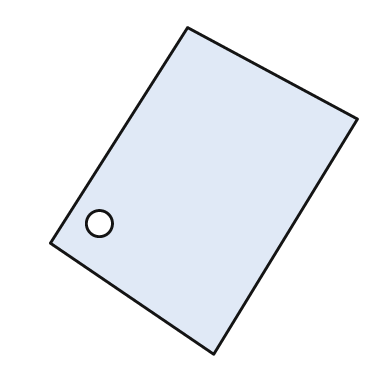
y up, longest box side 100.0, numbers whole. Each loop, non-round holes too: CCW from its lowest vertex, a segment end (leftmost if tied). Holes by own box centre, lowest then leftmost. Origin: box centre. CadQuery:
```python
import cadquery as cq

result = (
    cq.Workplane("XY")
    .moveTo(3.0, -50.0)
    .lineTo(47.0, 22.0)
    .lineTo(-5.0, 50.0)
    .lineTo(-47.0, -16.0)
    .close()
    .moveTo(-32.0, -10.0)
    .circle(4.0)
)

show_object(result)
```